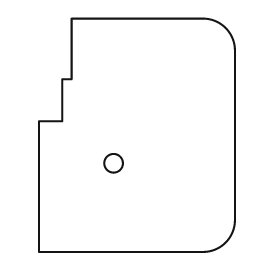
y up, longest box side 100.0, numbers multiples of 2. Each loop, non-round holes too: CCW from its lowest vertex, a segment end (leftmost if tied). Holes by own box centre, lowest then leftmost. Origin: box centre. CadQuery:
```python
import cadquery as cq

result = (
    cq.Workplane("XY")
    .moveTo(-42.0, -50.0)
    .lineTo(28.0, -50.0)
    .threePointArc((38.0, -46.0), (42.0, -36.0))
    .lineTo(42.0, 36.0)
    .threePointArc((38.0, 46.0), (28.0, 50.0))
    .lineTo(-28.0, 50.0)
    .lineTo(-28.0, 24.0)
    .lineTo(-32.0, 24.0)
    .lineTo(-32.0, 6.0)
    .lineTo(-42.0, 6.0)
    .close()
    .moveTo(-10.0, -12.0)
    .circle(4.0)
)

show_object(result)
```